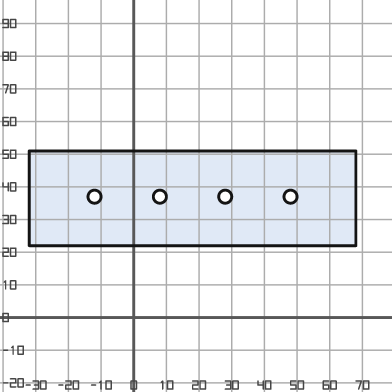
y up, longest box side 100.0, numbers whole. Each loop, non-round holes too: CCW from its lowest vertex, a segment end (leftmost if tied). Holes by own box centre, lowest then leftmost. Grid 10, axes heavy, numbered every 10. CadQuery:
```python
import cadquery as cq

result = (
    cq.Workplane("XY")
    .moveTo(-32.0, 22.0)
    .lineTo(68.0, 22.0)
    .lineTo(68.0, 51.0)
    .lineTo(-32.0, 51.0)
    .close()
    .moveTo(-12.0, 37.0)
    .circle(2.0)
    .moveTo(8.0, 37.0)
    .circle(2.0)
    .moveTo(28.0, 37.0)
    .circle(2.0)
    .moveTo(48.0, 37.0)
    .circle(2.0)
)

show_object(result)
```